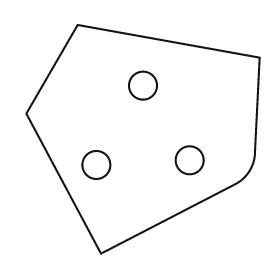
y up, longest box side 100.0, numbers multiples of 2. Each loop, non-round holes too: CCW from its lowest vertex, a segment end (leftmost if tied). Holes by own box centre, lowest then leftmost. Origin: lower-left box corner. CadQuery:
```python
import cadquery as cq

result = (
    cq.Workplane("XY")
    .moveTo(32.0, 0.0)
    .lineTo(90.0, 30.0)
    .threePointArc((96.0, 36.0), (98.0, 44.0))
    .lineTo(100.0, 84.0)
    .lineTo(22.0, 98.0)
    .lineTo(0.0, 60.0)
    .close()
    .moveTo(30.0, 38.0)
    .circle(6.0)
    .moveTo(70.0, 40.0)
    .circle(6.0)
    .moveTo(50.0, 72.0)
    .circle(6.0)
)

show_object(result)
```